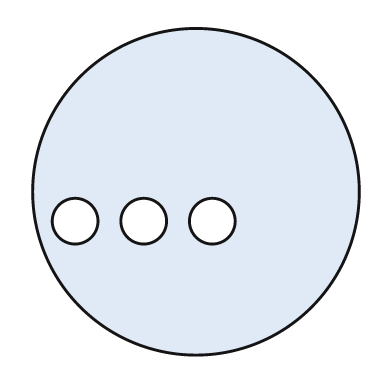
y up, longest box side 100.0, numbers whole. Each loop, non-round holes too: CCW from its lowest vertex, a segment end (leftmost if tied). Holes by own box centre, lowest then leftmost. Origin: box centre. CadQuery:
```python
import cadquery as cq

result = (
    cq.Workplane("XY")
    .moveTo(0.0, 0.0)
    .circle(50.0)
    .moveTo(-37.0, -9.0)
    .circle(7.0)
    .moveTo(-16.0, -9.0)
    .circle(7.0)
    .moveTo(5.0, -9.0)
    .circle(7.0)
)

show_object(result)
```